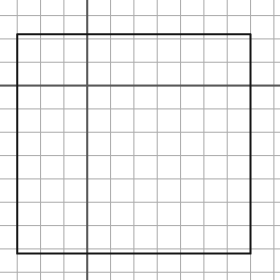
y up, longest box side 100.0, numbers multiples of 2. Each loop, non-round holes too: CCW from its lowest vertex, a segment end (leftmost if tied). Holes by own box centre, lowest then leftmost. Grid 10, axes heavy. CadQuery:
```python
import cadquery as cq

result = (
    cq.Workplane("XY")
    .moveTo(-30.0, -72.0)
    .lineTo(70.0, -72.0)
    .lineTo(70.0, 22.0)
    .lineTo(-30.0, 22.0)
    .close()
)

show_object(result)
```